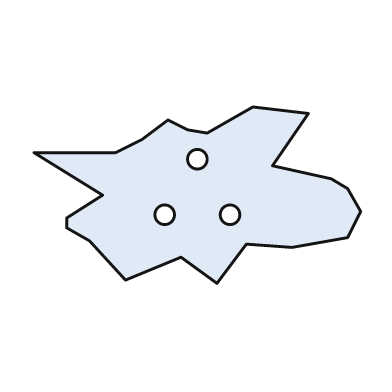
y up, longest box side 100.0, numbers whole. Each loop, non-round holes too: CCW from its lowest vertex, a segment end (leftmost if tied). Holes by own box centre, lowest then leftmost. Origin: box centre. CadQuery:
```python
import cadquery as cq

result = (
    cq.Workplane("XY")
    .moveTo(6.0, -27.0)
    .lineTo(15.0, -15.0)
    .lineTo(29.0, -16.0)
    .lineTo(46.0, -13.0)
    .lineTo(50.0, -5.0)
    .lineTo(46.0, 2.0)
    .lineTo(41.0, 5.0)
    .lineTo(23.0, 9.0)
    .lineTo(34.0, 25.0)
    .lineTo(17.0, 27.0)
    .lineTo(3.0, 19.0)
    .lineTo(-3.0, 20.0)
    .lineTo(-9.0, 23.0)
    .lineTo(-17.0, 17.0)
    .lineTo(-25.0, 13.0)
    .lineTo(-50.0, 13.0)
    .lineTo(-29.0, 0.0)
    .lineTo(-40.0, -7.0)
    .lineTo(-40.0, -10.0)
    .lineTo(-33.0, -14.0)
    .lineTo(-22.0, -26.0)
    .lineTo(-5.0, -19.0)
    .close()
    .moveTo(-10.0, -6.0)
    .circle(3.0)
    .moveTo(10.0, -6.0)
    .circle(3.0)
    .moveTo(0.0, 11.0)
    .circle(3.0)
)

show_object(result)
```